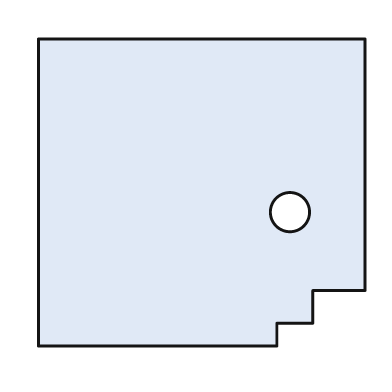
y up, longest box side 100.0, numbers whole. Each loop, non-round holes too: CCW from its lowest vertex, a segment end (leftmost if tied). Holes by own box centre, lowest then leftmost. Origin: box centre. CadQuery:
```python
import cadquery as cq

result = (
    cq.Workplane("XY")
    .moveTo(-50.0, -47.0)
    .lineTo(23.0, -47.0)
    .lineTo(23.0, -40.0)
    .lineTo(34.0, -40.0)
    .lineTo(34.0, -30.0)
    .lineTo(50.0, -30.0)
    .lineTo(50.0, 47.0)
    .lineTo(-50.0, 47.0)
    .close()
    .moveTo(27.0, -6.0)
    .circle(6.0)
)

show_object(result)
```